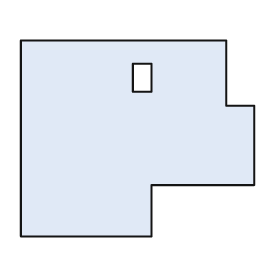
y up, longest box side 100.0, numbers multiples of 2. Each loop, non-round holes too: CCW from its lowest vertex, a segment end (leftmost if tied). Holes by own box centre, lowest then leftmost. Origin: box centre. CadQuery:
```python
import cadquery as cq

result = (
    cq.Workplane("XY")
    .moveTo(-50.0, -42.0)
    .lineTo(6.0, -42.0)
    .lineTo(6.0, -20.0)
    .lineTo(50.0, -20.0)
    .lineTo(50.0, 14.0)
    .lineTo(38.0, 14.0)
    .lineTo(38.0, 42.0)
    .lineTo(-50.0, 42.0)
    .close()
    .moveTo(-2.0, 20.0)
    .lineTo(6.0, 20.0)
    .lineTo(6.0, 32.0)
    .lineTo(-2.0, 32.0)
    .close()
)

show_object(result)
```